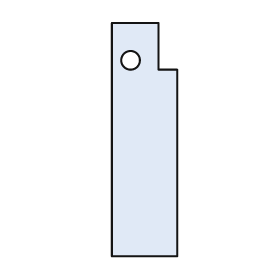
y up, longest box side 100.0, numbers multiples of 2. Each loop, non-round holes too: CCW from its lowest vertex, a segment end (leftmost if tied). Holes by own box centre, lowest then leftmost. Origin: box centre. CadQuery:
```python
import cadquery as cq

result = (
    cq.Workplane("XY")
    .moveTo(-14.0, -50.0)
    .lineTo(14.0, -50.0)
    .lineTo(14.0, 30.0)
    .lineTo(6.0, 30.0)
    .lineTo(6.0, 50.0)
    .lineTo(-14.0, 50.0)
    .close()
    .moveTo(-6.0, 34.0)
    .circle(4.0)
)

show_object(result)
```